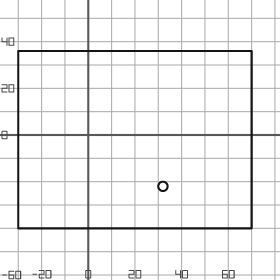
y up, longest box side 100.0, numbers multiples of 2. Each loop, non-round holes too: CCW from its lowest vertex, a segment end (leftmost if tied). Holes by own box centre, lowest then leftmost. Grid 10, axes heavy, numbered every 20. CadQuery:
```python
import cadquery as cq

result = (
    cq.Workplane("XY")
    .moveTo(-30.0, -40.0)
    .lineTo(70.0, -40.0)
    .lineTo(70.0, 36.0)
    .lineTo(-30.0, 36.0)
    .close()
    .moveTo(32.0, -22.0)
    .circle(2.0)
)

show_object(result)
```